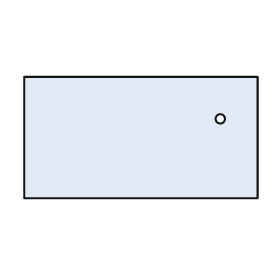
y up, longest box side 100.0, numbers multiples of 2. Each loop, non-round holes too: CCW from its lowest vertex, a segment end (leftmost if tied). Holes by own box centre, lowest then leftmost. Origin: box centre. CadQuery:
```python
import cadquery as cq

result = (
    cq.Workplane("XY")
    .moveTo(-50.0, -26.0)
    .lineTo(50.0, -26.0)
    .lineTo(50.0, 26.0)
    .lineTo(-50.0, 26.0)
    .close()
    .moveTo(34.0, 8.0)
    .circle(2.0)
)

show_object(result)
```